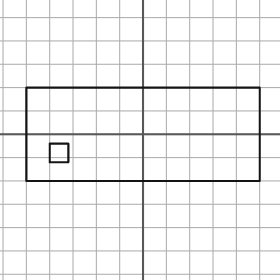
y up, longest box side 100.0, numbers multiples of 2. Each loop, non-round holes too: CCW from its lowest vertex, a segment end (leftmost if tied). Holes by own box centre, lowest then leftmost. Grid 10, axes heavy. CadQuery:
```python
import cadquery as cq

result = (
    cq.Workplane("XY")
    .moveTo(-50.0, -20.0)
    .lineTo(50.0, -20.0)
    .lineTo(50.0, 20.0)
    .lineTo(-50.0, 20.0)
    .close()
    .moveTo(-40.0, -12.0)
    .lineTo(-32.0, -12.0)
    .lineTo(-32.0, -4.0)
    .lineTo(-40.0, -4.0)
    .close()
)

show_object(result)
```